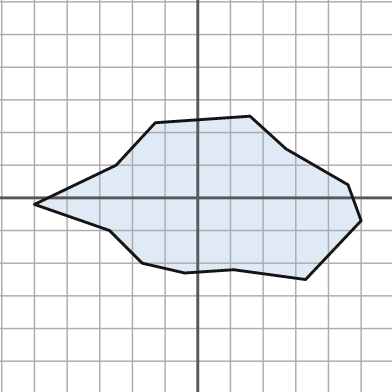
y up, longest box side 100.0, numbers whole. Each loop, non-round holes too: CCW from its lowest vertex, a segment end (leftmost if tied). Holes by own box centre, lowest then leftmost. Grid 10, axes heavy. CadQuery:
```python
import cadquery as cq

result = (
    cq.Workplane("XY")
    .moveTo(33.0, -25.0)
    .lineTo(50.0, -7.0)
    .lineTo(46.0, 4.0)
    .lineTo(27.0, 15.0)
    .lineTo(16.0, 25.0)
    .lineTo(-13.0, 23.0)
    .lineTo(-25.0, 10.0)
    .lineTo(-50.0, -2.0)
    .lineTo(-27.0, -10.0)
    .lineTo(-17.0, -20.0)
    .lineTo(-4.0, -23.0)
    .lineTo(11.0, -22.0)
    .close()
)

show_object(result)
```